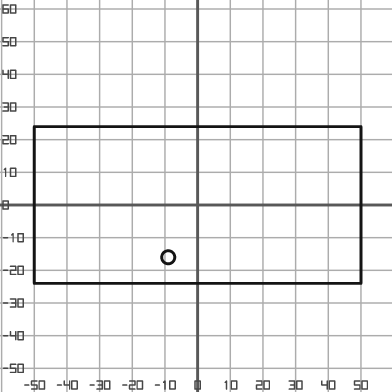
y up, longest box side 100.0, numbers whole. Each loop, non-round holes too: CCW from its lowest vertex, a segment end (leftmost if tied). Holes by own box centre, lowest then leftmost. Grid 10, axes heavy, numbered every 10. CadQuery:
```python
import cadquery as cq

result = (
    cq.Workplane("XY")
    .moveTo(-50.0, -24.0)
    .lineTo(50.0, -24.0)
    .lineTo(50.0, 24.0)
    .lineTo(-50.0, 24.0)
    .close()
    .moveTo(-9.0, -16.0)
    .circle(2.0)
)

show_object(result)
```